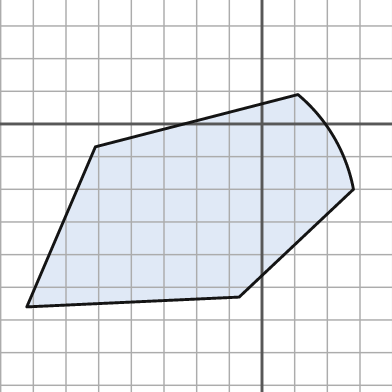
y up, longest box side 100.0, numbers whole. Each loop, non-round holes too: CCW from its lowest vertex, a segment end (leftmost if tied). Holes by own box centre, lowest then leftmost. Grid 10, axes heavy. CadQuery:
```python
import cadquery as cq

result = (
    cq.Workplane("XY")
    .moveTo(-72.0, -56.0)
    .lineTo(-7.0, -53.0)
    .lineTo(28.0, -20.0)
    .threePointArc((22.0, -4.0), (11.0, 9.0))
    .lineTo(-51.0, -7.0)
    .close()
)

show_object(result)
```